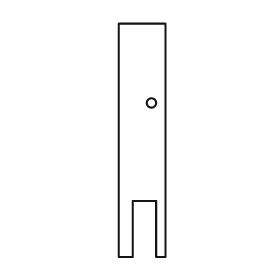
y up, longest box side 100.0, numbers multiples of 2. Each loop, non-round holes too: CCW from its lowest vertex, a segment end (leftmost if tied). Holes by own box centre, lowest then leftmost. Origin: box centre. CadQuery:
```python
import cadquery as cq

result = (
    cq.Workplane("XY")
    .moveTo(-10.0, -50.0)
    .lineTo(-4.0, -50.0)
    .lineTo(-4.0, -26.0)
    .lineTo(6.0, -26.0)
    .lineTo(6.0, -50.0)
    .lineTo(10.0, -50.0)
    .lineTo(10.0, 50.0)
    .lineTo(-10.0, 50.0)
    .close()
    .moveTo(4.0, 16.0)
    .circle(2.0)
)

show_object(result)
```